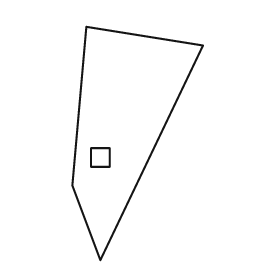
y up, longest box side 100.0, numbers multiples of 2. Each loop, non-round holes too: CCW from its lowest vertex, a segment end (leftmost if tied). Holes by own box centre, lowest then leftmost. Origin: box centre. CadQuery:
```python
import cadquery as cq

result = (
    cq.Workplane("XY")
    .moveTo(-16.0, -50.0)
    .lineTo(28.0, 42.0)
    .lineTo(-22.0, 50.0)
    .lineTo(-28.0, -18.0)
    .close()
    .moveTo(-20.0, -10.0)
    .lineTo(-12.0, -10.0)
    .lineTo(-12.0, -2.0)
    .lineTo(-20.0, -2.0)
    .close()
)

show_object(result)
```